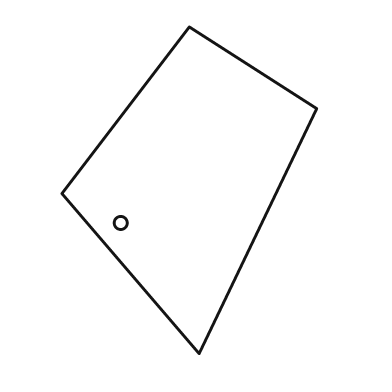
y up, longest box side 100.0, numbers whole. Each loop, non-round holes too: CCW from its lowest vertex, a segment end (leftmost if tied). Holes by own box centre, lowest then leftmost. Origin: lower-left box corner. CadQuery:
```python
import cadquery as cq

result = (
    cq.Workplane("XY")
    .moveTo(42.0, 0.0)
    .lineTo(78.0, 75.0)
    .lineTo(39.0, 100.0)
    .lineTo(0.0, 49.0)
    .close()
    .moveTo(18.0, 40.0)
    .circle(2.0)
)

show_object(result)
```